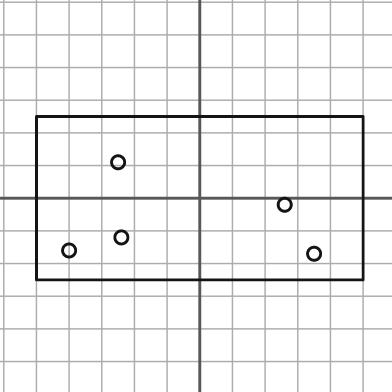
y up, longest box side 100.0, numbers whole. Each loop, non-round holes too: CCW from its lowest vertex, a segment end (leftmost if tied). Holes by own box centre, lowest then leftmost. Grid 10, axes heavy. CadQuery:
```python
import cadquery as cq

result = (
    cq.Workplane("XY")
    .moveTo(-50.0, -25.0)
    .lineTo(50.0, -25.0)
    .lineTo(50.0, 25.0)
    .lineTo(-50.0, 25.0)
    .close()
    .moveTo(35.0, -17.0)
    .circle(2.0)
    .moveTo(-40.0, -16.0)
    .circle(2.0)
    .moveTo(-24.0, -12.0)
    .circle(2.0)
    .moveTo(26.0, -2.0)
    .circle(2.0)
    .moveTo(-25.0, 11.0)
    .circle(2.0)
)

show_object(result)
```